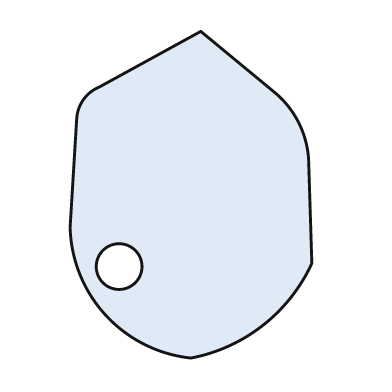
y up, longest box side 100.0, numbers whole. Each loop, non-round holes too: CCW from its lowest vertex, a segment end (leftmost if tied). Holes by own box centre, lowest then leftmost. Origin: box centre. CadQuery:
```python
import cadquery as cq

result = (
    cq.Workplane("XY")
    .moveTo(0.0, -50.0)
    .threePointArc((22.0, -40.0), (37.0, -21.0))
    .lineTo(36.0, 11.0)
    .threePointArc((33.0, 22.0), (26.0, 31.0))
    .lineTo(3.0, 50.0)
    .lineTo(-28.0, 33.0)
    .threePointArc((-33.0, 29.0), (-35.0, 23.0))
    .lineTo(-37.0, -10.0)
    .threePointArc((-26.0, -37.0), (0.0, -50.0))
    .close()
    .moveTo(-22.0, -22.0)
    .circle(7.0)
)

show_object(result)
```